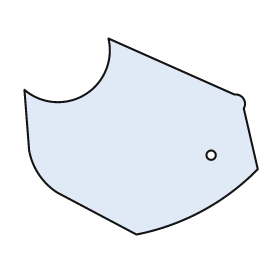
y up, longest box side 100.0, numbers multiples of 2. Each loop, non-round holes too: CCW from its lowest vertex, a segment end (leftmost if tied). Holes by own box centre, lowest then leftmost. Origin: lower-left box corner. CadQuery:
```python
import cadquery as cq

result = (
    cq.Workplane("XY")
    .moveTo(48.0, 0.0)
    .threePointArc((76.0, 10.0), (100.0, 28.0))
    .lineTo(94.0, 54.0)
    .threePointArc((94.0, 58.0), (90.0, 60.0))
    .lineTo(36.0, 84.0)
    .threePointArc((26.0, 60.0), (0.0, 62.0))
    .lineTo(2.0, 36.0)
    .threePointArc((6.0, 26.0), (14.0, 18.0))
    .close()
    .moveTo(80.0, 34.0)
    .circle(2.0)
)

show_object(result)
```